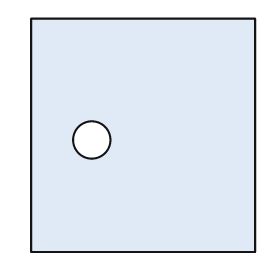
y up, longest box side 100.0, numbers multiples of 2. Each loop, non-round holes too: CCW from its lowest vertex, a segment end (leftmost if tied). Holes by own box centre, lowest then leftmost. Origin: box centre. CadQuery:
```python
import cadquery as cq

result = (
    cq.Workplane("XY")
    .moveTo(-48.0, -50.0)
    .lineTo(48.0, -50.0)
    .lineTo(48.0, 50.0)
    .lineTo(-48.0, 50.0)
    .close()
    .moveTo(-22.0, -2.0)
    .circle(8.0)
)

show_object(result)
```